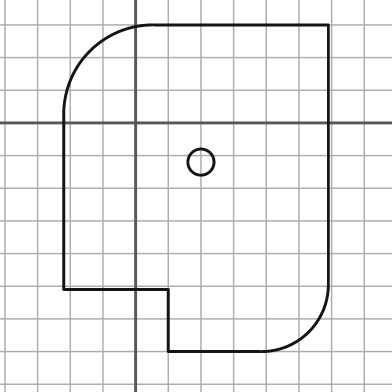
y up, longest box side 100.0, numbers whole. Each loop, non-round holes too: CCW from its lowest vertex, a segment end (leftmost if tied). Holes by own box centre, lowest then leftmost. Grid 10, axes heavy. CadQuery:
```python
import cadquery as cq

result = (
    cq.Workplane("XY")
    .moveTo(10.0, -70.0)
    .lineTo(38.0, -70.0)
    .threePointArc((53.0, -64.0), (59.0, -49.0))
    .lineTo(59.0, 30.0)
    .lineTo(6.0, 30.0)
    .threePointArc((-14.0, 22.0), (-22.0, 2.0))
    .lineTo(-22.0, -51.0)
    .lineTo(10.0, -51.0)
    .close()
    .moveTo(20.0, -12.0)
    .circle(4.0)
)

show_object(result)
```